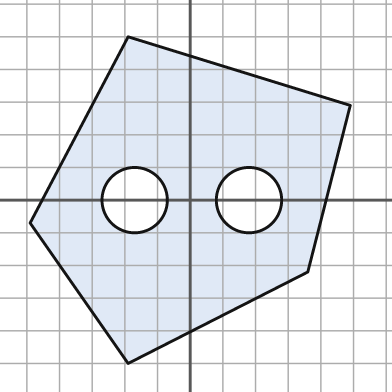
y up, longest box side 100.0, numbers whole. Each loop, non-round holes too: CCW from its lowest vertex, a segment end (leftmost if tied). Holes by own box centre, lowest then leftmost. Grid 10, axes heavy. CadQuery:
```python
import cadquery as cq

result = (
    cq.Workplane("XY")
    .moveTo(-19.0, -50.0)
    .lineTo(36.0, -22.0)
    .lineTo(49.0, 29.0)
    .lineTo(-19.0, 50.0)
    .lineTo(-49.0, -7.0)
    .close()
    .moveTo(-17.0, 0.0)
    .circle(10.0)
    .moveTo(18.0, 0.0)
    .circle(10.0)
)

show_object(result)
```